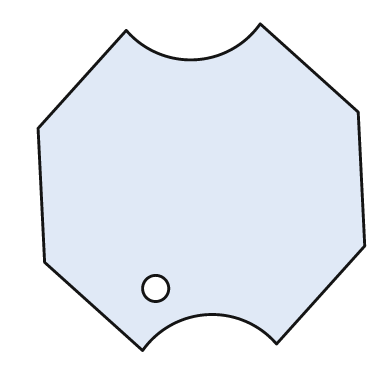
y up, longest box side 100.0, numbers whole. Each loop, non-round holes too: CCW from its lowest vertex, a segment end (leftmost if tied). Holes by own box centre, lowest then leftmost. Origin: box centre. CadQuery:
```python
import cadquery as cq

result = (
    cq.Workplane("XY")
    .moveTo(-18.0, -50.0)
    .threePointArc((2.0, -39.0), (23.0, -48.0))
    .lineTo(50.0, -18.0)
    .lineTo(48.0, 23.0)
    .lineTo(18.0, 50.0)
    .threePointArc((-2.0, 39.0), (-23.0, 48.0))
    .lineTo(-50.0, 18.0)
    .lineTo(-48.0, -23.0)
    .close()
    .moveTo(-14.0, -31.0)
    .circle(4.0)
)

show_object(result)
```